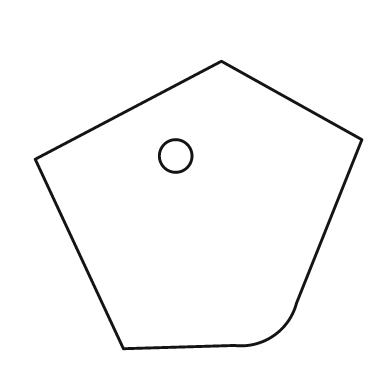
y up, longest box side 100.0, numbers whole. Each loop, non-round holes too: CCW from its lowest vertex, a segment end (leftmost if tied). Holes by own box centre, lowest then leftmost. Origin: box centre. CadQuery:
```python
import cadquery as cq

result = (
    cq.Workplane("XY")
    .moveTo(-23.0, -44.0)
    .lineTo(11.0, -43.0)
    .threePointArc((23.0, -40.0), (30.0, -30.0))
    .lineTo(50.0, 20.0)
    .lineTo(7.0, 44.0)
    .lineTo(-50.0, 14.0)
    .close()
    .moveTo(-7.0, 15.0)
    .circle(5.0)
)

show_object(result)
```